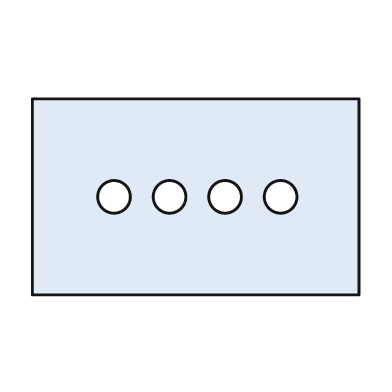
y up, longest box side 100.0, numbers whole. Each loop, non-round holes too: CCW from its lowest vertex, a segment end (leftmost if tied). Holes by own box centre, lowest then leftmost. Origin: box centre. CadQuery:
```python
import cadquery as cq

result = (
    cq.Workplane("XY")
    .moveTo(-50.0, -30.0)
    .lineTo(50.0, -30.0)
    .lineTo(50.0, 30.0)
    .lineTo(-50.0, 30.0)
    .close()
    .moveTo(-25.0, 0.0)
    .circle(5.0)
    .moveTo(-8.0, 0.0)
    .circle(5.0)
    .moveTo(9.0, 0.0)
    .circle(5.0)
    .moveTo(26.0, 0.0)
    .circle(5.0)
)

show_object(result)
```